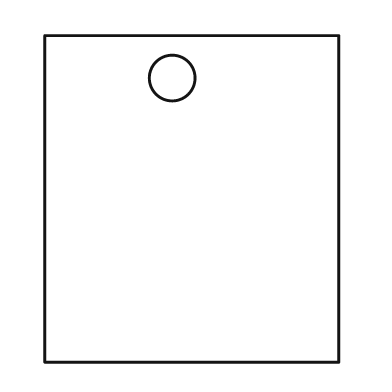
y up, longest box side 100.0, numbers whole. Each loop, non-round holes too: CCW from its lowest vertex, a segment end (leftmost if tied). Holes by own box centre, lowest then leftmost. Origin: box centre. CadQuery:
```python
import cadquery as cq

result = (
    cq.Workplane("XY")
    .moveTo(-45.0, -50.0)
    .lineTo(45.0, -50.0)
    .lineTo(45.0, 50.0)
    .lineTo(-45.0, 50.0)
    .close()
    .moveTo(-6.0, 37.0)
    .circle(7.0)
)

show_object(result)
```